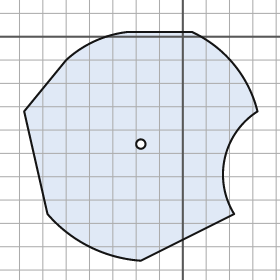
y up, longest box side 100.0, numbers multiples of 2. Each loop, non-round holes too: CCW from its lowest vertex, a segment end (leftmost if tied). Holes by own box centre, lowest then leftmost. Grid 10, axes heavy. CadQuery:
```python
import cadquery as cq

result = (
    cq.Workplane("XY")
    .moveTo(-18.0, -96.0)
    .lineTo(22.0, -76.0)
    .threePointArc((18.0, -52.0), (32.0, -32.0))
    .threePointArc((22.0, -12.0), (4.0, 2.0))
    .lineTo(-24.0, 2.0)
    .threePointArc((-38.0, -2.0), (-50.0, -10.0))
    .lineTo(-68.0, -32.0)
    .lineTo(-58.0, -76.0)
    .threePointArc((-40.0, -90.0), (-18.0, -96.0))
    .close()
    .moveTo(-18.0, -46.0)
    .circle(2.0)
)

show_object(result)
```